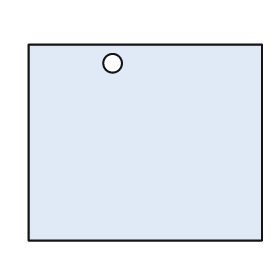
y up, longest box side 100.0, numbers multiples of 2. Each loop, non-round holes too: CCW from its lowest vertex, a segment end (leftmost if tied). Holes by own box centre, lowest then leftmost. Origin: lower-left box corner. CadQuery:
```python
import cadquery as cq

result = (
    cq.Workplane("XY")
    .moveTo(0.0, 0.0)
    .lineTo(100.0, 0.0)
    .lineTo(100.0, 84.0)
    .lineTo(0.0, 84.0)
    .close()
    .moveTo(36.0, 76.0)
    .circle(4.0)
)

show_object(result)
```